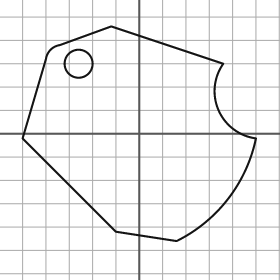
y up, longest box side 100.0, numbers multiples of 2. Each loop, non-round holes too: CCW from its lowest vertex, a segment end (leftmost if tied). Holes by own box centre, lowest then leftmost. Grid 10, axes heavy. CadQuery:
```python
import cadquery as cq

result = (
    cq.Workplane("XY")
    .moveTo(16.0, -46.0)
    .threePointArc((38.0, -28.0), (50.0, -2.0))
    .threePointArc((34.0, 10.0), (36.0, 30.0))
    .lineTo(-12.0, 46.0)
    .lineTo(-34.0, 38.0)
    .threePointArc((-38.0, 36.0), (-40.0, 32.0))
    .lineTo(-50.0, -2.0)
    .lineTo(-10.0, -42.0)
    .close()
    .moveTo(-26.0, 30.0)
    .circle(6.0)
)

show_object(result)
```